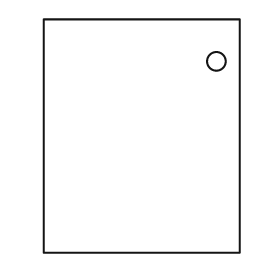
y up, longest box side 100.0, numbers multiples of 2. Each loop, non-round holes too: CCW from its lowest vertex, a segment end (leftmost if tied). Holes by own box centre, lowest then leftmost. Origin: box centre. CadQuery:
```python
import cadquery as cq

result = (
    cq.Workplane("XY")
    .moveTo(-42.0, -50.0)
    .lineTo(42.0, -50.0)
    .lineTo(42.0, 50.0)
    .lineTo(-42.0, 50.0)
    .close()
    .moveTo(32.0, 32.0)
    .circle(4.0)
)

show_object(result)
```